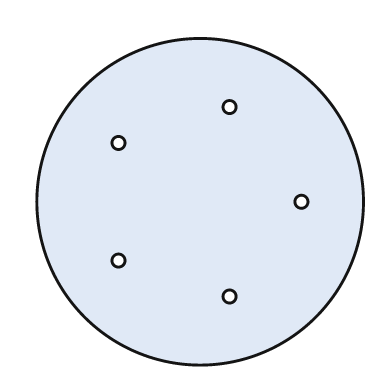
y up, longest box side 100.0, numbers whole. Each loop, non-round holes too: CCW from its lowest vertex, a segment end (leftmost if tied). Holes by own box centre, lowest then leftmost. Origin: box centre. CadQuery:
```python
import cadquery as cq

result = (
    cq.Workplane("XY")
    .moveTo(0.0, 0.0)
    .circle(50.0)
    .moveTo(9.0, -29.0)
    .circle(2.0)
    .moveTo(-25.0, -18.0)
    .circle(2.0)
    .moveTo(31.0, 0.0)
    .circle(2.0)
    .moveTo(-25.0, 18.0)
    .circle(2.0)
    .moveTo(9.0, 29.0)
    .circle(2.0)
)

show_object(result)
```